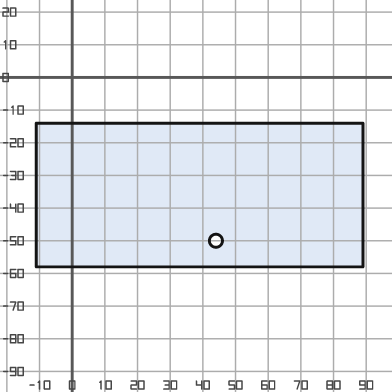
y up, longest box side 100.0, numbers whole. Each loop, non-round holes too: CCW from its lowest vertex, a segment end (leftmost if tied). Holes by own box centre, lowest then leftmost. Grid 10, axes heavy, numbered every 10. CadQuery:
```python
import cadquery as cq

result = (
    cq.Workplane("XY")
    .moveTo(-11.0, -58.0)
    .lineTo(89.0, -58.0)
    .lineTo(89.0, -14.0)
    .lineTo(-11.0, -14.0)
    .close()
    .moveTo(44.0, -50.0)
    .circle(2.0)
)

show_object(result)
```